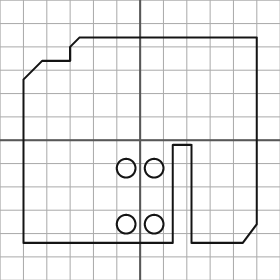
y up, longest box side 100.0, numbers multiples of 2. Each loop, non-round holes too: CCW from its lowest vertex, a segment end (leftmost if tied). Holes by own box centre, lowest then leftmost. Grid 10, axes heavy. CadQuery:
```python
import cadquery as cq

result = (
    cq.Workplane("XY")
    .moveTo(-50.0, -44.0)
    .lineTo(14.0, -44.0)
    .lineTo(14.0, -2.0)
    .lineTo(22.0, -2.0)
    .lineTo(22.0, -44.0)
    .lineTo(44.0, -44.0)
    .lineTo(50.0, -36.0)
    .lineTo(50.0, 44.0)
    .lineTo(-26.0, 44.0)
    .lineTo(-30.0, 40.0)
    .lineTo(-30.0, 34.0)
    .lineTo(-42.0, 34.0)
    .lineTo(-50.0, 26.0)
    .close()
    .moveTo(-6.0, -36.0)
    .circle(4.0)
    .moveTo(6.0, -36.0)
    .circle(4.0)
    .moveTo(-6.0, -12.0)
    .circle(4.0)
    .moveTo(6.0, -12.0)
    .circle(4.0)
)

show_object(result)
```